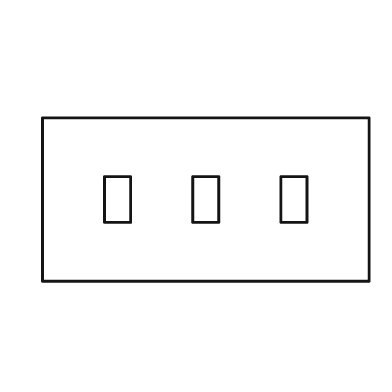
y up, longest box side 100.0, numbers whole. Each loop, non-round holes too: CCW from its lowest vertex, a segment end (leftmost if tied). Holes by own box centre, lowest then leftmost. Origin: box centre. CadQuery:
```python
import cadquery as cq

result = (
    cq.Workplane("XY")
    .moveTo(-50.0, -25.0)
    .lineTo(50.0, -25.0)
    .lineTo(50.0, 25.0)
    .lineTo(-50.0, 25.0)
    .close()
    .moveTo(-31.0, -7.0)
    .lineTo(-23.0, -7.0)
    .lineTo(-23.0, 7.0)
    .lineTo(-31.0, 7.0)
    .close()
    .moveTo(-4.0, -7.0)
    .lineTo(4.0, -7.0)
    .lineTo(4.0, 7.0)
    .lineTo(-4.0, 7.0)
    .close()
    .moveTo(23.0, -7.0)
    .lineTo(31.0, -7.0)
    .lineTo(31.0, 7.0)
    .lineTo(23.0, 7.0)
    .close()
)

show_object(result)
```